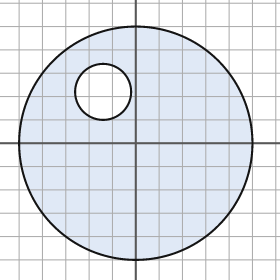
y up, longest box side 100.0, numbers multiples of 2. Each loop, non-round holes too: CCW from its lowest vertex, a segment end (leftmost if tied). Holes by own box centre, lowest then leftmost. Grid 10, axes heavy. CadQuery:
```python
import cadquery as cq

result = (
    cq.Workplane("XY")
    .moveTo(0.0, 0.0)
    .circle(50.0)
    .moveTo(-14.0, 22.0)
    .circle(12.0)
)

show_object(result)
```